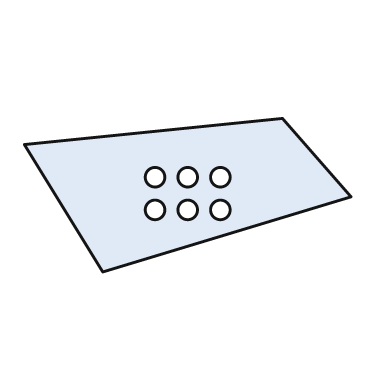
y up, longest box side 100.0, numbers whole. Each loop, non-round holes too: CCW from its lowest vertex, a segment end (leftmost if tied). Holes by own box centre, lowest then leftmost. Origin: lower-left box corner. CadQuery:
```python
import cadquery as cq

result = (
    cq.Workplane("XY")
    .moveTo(24.0, 0.0)
    .lineTo(100.0, 23.0)
    .lineTo(79.0, 47.0)
    .lineTo(0.0, 39.0)
    .close()
    .moveTo(40.0, 19.0)
    .circle(3.0)
    .moveTo(50.0, 19.0)
    .circle(3.0)
    .moveTo(60.0, 19.0)
    .circle(3.0)
    .moveTo(40.0, 29.0)
    .circle(3.0)
    .moveTo(50.0, 29.0)
    .circle(3.0)
    .moveTo(60.0, 29.0)
    .circle(3.0)
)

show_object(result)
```